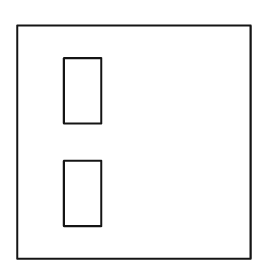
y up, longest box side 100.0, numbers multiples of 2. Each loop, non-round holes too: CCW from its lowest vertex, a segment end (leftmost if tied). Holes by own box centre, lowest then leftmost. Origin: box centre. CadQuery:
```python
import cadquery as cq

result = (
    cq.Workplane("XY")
    .moveTo(-50.0, -50.0)
    .lineTo(50.0, -50.0)
    .lineTo(50.0, 50.0)
    .lineTo(-50.0, 50.0)
    .close()
    .moveTo(-30.0, -36.0)
    .lineTo(-14.0, -36.0)
    .lineTo(-14.0, -8.0)
    .lineTo(-30.0, -8.0)
    .close()
    .moveTo(-30.0, 8.0)
    .lineTo(-14.0, 8.0)
    .lineTo(-14.0, 36.0)
    .lineTo(-30.0, 36.0)
    .close()
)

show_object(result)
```